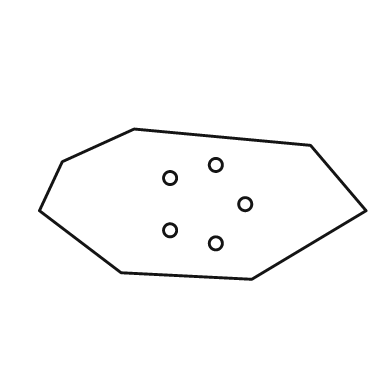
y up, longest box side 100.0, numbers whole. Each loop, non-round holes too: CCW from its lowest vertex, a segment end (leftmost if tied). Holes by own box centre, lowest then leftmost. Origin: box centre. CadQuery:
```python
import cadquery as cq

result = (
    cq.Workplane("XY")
    .moveTo(15.0, -23.0)
    .lineTo(50.0, -2.0)
    .lineTo(33.0, 18.0)
    .lineTo(-21.0, 23.0)
    .lineTo(-43.0, 13.0)
    .lineTo(-50.0, -2.0)
    .lineTo(-25.0, -21.0)
    .close()
    .moveTo(4.0, -12.0)
    .circle(2.0)
    .moveTo(-10.0, -8.0)
    .circle(2.0)
    .moveTo(13.0, 0.0)
    .circle(2.0)
    .moveTo(-10.0, 8.0)
    .circle(2.0)
    .moveTo(4.0, 12.0)
    .circle(2.0)
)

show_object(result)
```